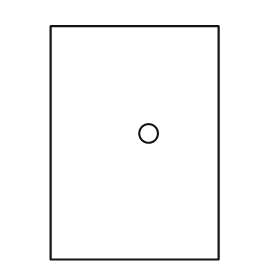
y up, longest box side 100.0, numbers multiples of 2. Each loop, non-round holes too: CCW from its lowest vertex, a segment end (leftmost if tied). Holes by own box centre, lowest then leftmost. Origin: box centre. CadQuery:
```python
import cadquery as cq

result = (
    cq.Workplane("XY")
    .moveTo(-36.0, -50.0)
    .lineTo(36.0, -50.0)
    .lineTo(36.0, 50.0)
    .lineTo(-36.0, 50.0)
    .close()
    .moveTo(6.0, 4.0)
    .circle(4.0)
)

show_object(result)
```